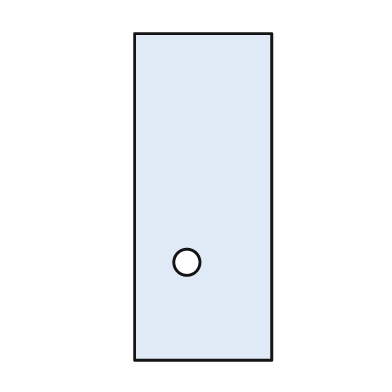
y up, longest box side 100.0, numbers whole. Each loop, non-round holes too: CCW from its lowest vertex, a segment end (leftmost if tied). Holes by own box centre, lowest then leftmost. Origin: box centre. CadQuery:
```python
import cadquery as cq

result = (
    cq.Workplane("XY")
    .moveTo(-21.0, -50.0)
    .lineTo(21.0, -50.0)
    .lineTo(21.0, 50.0)
    .lineTo(-21.0, 50.0)
    .close()
    .moveTo(-5.0, -20.0)
    .circle(4.0)
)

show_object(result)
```